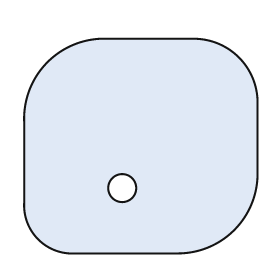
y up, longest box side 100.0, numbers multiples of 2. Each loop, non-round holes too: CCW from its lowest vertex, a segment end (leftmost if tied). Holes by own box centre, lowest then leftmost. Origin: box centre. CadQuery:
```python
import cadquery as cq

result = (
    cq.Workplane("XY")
    .moveTo(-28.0, -46.0)
    .lineTo(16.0, -46.0)
    .threePointArc((40.0, -36.0), (50.0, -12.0))
    .lineTo(50.0, 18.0)
    .threePointArc((42.0, 38.0), (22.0, 46.0))
    .lineTo(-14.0, 46.0)
    .threePointArc((-40.0, 36.0), (-50.0, 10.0))
    .lineTo(-50.0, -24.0)
    .threePointArc((-44.0, -40.0), (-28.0, -46.0))
    .close()
    .moveTo(-8.0, -18.0)
    .circle(6.0)
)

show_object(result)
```